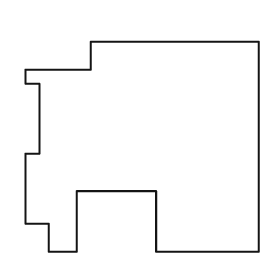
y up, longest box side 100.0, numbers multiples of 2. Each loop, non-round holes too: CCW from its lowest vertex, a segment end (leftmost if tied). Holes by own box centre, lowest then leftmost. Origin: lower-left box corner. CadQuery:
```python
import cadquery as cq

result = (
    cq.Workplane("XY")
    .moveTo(10.0, 0.0)
    .lineTo(22.0, 0.0)
    .lineTo(22.0, 26.0)
    .lineTo(56.0, 26.0)
    .lineTo(56.0, 0.0)
    .lineTo(100.0, 0.0)
    .lineTo(100.0, 90.0)
    .lineTo(28.0, 90.0)
    .lineTo(28.0, 78.0)
    .lineTo(0.0, 78.0)
    .lineTo(0.0, 72.0)
    .lineTo(6.0, 72.0)
    .lineTo(6.0, 42.0)
    .lineTo(0.0, 42.0)
    .lineTo(0.0, 12.0)
    .lineTo(10.0, 12.0)
    .close()
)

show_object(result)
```